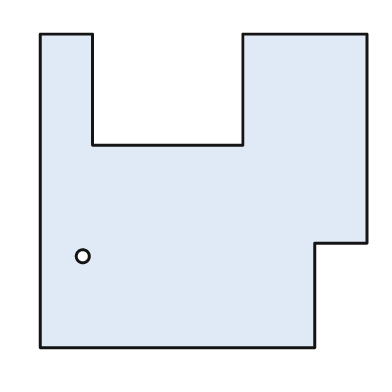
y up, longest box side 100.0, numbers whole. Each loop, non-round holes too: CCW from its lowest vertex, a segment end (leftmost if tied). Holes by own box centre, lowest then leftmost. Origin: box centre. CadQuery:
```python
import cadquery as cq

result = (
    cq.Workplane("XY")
    .moveTo(-50.0, -48.0)
    .lineTo(34.0, -48.0)
    .lineTo(34.0, -16.0)
    .lineTo(50.0, -16.0)
    .lineTo(50.0, 48.0)
    .lineTo(12.0, 48.0)
    .lineTo(12.0, 14.0)
    .lineTo(-34.0, 14.0)
    .lineTo(-34.0, 48.0)
    .lineTo(-50.0, 48.0)
    .close()
    .moveTo(-37.0, -20.0)
    .circle(2.0)
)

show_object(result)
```